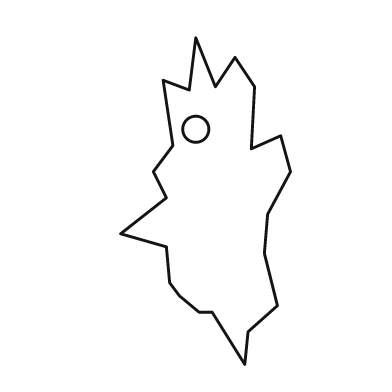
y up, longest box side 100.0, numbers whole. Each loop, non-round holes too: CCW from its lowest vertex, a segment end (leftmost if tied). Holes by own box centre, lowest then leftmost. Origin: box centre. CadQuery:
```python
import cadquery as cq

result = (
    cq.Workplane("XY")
    .moveTo(12.0, -50.0)
    .lineTo(13.0, -40.0)
    .lineTo(22.0, -32.0)
    .lineTo(18.0, -16.0)
    .lineTo(19.0, -4.0)
    .lineTo(26.0, 9.0)
    .lineTo(23.0, 20.0)
    .lineTo(14.0, 16.0)
    .lineTo(15.0, 35.0)
    .lineTo(9.0, 44.0)
    .lineTo(3.0, 35.0)
    .lineTo(-3.0, 50.0)
    .lineTo(-5.0, 34.0)
    .lineTo(-13.0, 37.0)
    .lineTo(-10.0, 17.0)
    .lineTo(-16.0, 9.0)
    .lineTo(-12.0, 1.0)
    .lineTo(-26.0, -10.0)
    .lineTo(-12.0, -14.0)
    .lineTo(-11.0, -25.0)
    .lineTo(-8.0, -29.0)
    .lineTo(-2.0, -34.0)
    .lineTo(2.0, -34.0)
    .close()
    .moveTo(-3.0, 22.0)
    .circle(4.0)
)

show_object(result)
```